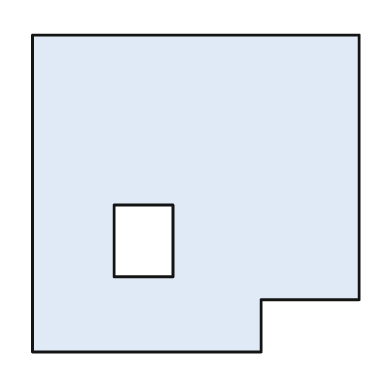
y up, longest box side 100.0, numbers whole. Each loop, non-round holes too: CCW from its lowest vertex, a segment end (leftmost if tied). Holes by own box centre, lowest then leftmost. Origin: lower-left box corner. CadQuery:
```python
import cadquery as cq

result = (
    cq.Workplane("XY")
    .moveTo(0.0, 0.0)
    .lineTo(70.0, 0.0)
    .lineTo(70.0, 16.0)
    .lineTo(100.0, 16.0)
    .lineTo(100.0, 97.0)
    .lineTo(0.0, 97.0)
    .close()
    .moveTo(25.0, 23.0)
    .lineTo(43.0, 23.0)
    .lineTo(43.0, 45.0)
    .lineTo(25.0, 45.0)
    .close()
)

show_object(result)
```